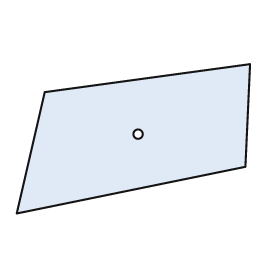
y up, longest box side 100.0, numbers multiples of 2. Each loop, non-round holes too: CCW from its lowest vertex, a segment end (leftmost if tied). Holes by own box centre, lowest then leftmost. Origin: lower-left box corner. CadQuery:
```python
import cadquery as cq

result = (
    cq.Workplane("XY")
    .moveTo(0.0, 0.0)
    .lineTo(98.0, 20.0)
    .lineTo(100.0, 64.0)
    .lineTo(12.0, 52.0)
    .close()
    .moveTo(52.0, 34.0)
    .circle(2.0)
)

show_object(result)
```